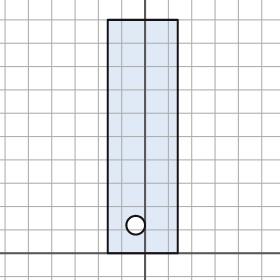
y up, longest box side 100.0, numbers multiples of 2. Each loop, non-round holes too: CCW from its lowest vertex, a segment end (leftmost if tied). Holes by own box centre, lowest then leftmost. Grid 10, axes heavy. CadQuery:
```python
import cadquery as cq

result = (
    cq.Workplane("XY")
    .moveTo(-16.0, 0.0)
    .lineTo(14.0, 0.0)
    .lineTo(14.0, 100.0)
    .lineTo(-16.0, 100.0)
    .close()
    .moveTo(-4.0, 12.0)
    .circle(4.0)
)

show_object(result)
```